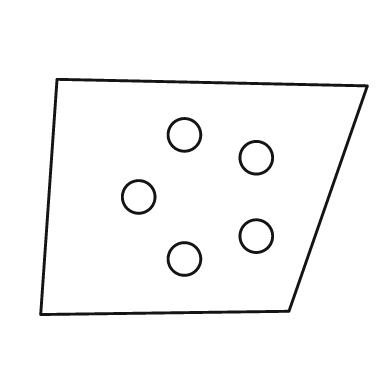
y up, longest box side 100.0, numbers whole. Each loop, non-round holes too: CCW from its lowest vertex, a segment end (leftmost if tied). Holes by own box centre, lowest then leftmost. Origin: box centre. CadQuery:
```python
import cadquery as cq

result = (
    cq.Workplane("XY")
    .moveTo(-50.0, -36.0)
    .lineTo(26.0, -35.0)
    .lineTo(50.0, 34.0)
    .lineTo(-45.0, 36.0)
    .close()
    .moveTo(-6.0, -19.0)
    .circle(5.0)
    .moveTo(16.0, -12.0)
    .circle(5.0)
    .moveTo(-20.0, 0.0)
    .circle(5.0)
    .moveTo(16.0, 12.0)
    .circle(5.0)
    .moveTo(-6.0, 19.0)
    .circle(5.0)
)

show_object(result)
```